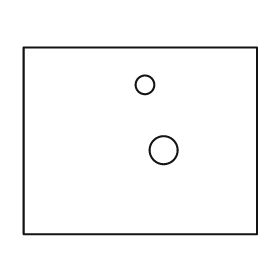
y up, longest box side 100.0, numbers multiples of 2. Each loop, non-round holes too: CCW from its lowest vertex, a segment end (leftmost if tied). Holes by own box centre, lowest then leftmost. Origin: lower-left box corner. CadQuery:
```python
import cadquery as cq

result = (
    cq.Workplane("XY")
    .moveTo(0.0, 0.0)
    .lineTo(100.0, 0.0)
    .lineTo(100.0, 80.0)
    .lineTo(0.0, 80.0)
    .close()
    .moveTo(60.0, 36.0)
    .circle(6.0)
    .moveTo(52.0, 64.0)
    .circle(4.0)
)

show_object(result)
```